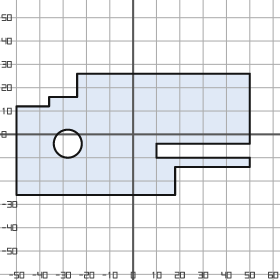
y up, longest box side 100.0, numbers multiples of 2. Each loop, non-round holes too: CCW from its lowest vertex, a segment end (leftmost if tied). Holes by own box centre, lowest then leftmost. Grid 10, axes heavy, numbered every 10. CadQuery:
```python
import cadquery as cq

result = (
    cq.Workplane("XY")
    .moveTo(-50.0, -26.0)
    .lineTo(18.0, -26.0)
    .lineTo(18.0, -14.0)
    .lineTo(50.0, -14.0)
    .lineTo(50.0, -10.0)
    .lineTo(10.0, -10.0)
    .lineTo(10.0, -4.0)
    .lineTo(50.0, -4.0)
    .lineTo(50.0, 26.0)
    .lineTo(-24.0, 26.0)
    .lineTo(-24.0, 16.0)
    .lineTo(-36.0, 16.0)
    .lineTo(-36.0, 12.0)
    .lineTo(-50.0, 12.0)
    .close()
    .moveTo(-28.0, -4.0)
    .circle(6.0)
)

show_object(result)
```